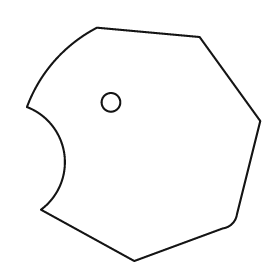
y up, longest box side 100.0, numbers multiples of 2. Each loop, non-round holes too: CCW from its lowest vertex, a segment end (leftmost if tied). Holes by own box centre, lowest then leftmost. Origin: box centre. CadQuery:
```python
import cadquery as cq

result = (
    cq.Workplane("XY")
    .moveTo(-4.0, -50.0)
    .lineTo(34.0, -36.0)
    .threePointArc((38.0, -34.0), (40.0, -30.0))
    .lineTo(50.0, 10.0)
    .lineTo(24.0, 46.0)
    .lineTo(-20.0, 50.0)
    .threePointArc((-38.0, 36.0), (-50.0, 16.0))
    .threePointArc((-34.0, -4.0), (-44.0, -28.0))
    .close()
    .moveTo(-14.0, 18.0)
    .circle(4.0)
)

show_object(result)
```